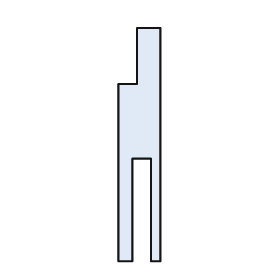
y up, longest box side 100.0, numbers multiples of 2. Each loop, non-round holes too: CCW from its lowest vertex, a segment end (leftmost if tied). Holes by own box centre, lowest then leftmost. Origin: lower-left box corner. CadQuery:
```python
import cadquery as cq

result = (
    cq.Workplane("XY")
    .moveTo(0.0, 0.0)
    .lineTo(6.0, 0.0)
    .lineTo(6.0, 44.0)
    .lineTo(14.0, 44.0)
    .lineTo(14.0, 0.0)
    .lineTo(18.0, 0.0)
    .lineTo(18.0, 100.0)
    .lineTo(8.0, 100.0)
    .lineTo(8.0, 76.0)
    .lineTo(0.0, 76.0)
    .close()
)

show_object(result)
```